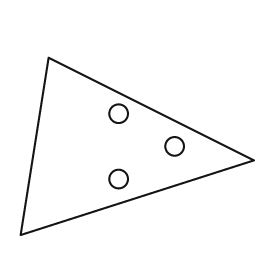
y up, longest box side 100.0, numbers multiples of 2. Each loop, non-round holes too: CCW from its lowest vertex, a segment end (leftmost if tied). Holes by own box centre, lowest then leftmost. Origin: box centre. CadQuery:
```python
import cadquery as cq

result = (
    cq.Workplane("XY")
    .moveTo(-50.0, -38.0)
    .lineTo(50.0, -6.0)
    .lineTo(-38.0, 38.0)
    .close()
    .moveTo(-8.0, -14.0)
    .circle(4.0)
    .moveTo(16.0, 0.0)
    .circle(4.0)
    .moveTo(-8.0, 14.0)
    .circle(4.0)
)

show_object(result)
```